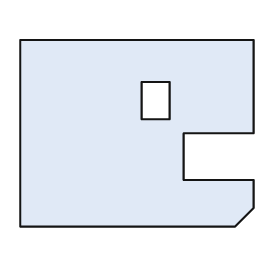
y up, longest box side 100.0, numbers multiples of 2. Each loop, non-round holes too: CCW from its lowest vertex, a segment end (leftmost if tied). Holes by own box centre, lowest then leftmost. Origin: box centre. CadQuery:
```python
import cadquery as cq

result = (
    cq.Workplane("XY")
    .moveTo(-50.0, -40.0)
    .lineTo(42.0, -40.0)
    .lineTo(50.0, -32.0)
    .lineTo(50.0, -20.0)
    .lineTo(20.0, -20.0)
    .lineTo(20.0, 0.0)
    .lineTo(50.0, 0.0)
    .lineTo(50.0, 40.0)
    .lineTo(-50.0, 40.0)
    .close()
    .moveTo(2.0, 6.0)
    .lineTo(14.0, 6.0)
    .lineTo(14.0, 22.0)
    .lineTo(2.0, 22.0)
    .close()
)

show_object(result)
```